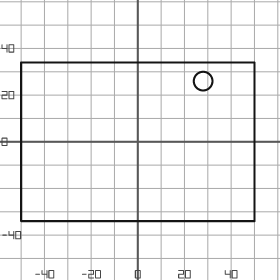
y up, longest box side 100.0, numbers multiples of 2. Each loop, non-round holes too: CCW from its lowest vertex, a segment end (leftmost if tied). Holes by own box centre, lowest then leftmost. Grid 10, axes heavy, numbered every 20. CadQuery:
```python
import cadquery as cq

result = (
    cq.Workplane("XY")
    .moveTo(-50.0, -34.0)
    .lineTo(50.0, -34.0)
    .lineTo(50.0, 34.0)
    .lineTo(-50.0, 34.0)
    .close()
    .moveTo(28.0, 26.0)
    .circle(4.0)
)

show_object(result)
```